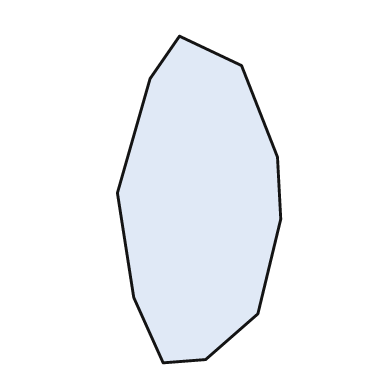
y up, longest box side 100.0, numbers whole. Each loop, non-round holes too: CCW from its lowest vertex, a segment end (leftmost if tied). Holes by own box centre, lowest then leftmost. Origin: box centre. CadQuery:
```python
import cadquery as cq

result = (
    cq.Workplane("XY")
    .moveTo(-11.0, -50.0)
    .lineTo(2.0, -49.0)
    .lineTo(18.0, -35.0)
    .lineTo(25.0, -6.0)
    .lineTo(24.0, 13.0)
    .lineTo(13.0, 41.0)
    .lineTo(-6.0, 50.0)
    .lineTo(-15.0, 37.0)
    .lineTo(-25.0, 2.0)
    .lineTo(-20.0, -30.0)
    .close()
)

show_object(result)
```